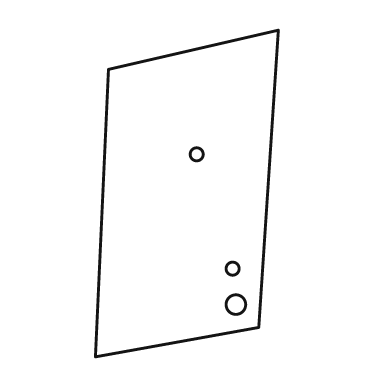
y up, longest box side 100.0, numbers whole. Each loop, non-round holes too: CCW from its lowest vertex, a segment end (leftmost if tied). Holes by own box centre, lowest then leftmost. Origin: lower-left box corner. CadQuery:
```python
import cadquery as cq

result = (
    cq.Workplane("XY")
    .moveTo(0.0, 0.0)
    .lineTo(50.0, 9.0)
    .lineTo(56.0, 100.0)
    .lineTo(4.0, 88.0)
    .close()
    .moveTo(43.0, 16.0)
    .circle(3.0)
    .moveTo(42.0, 27.0)
    .circle(2.0)
    .moveTo(31.0, 62.0)
    .circle(2.0)
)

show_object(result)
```